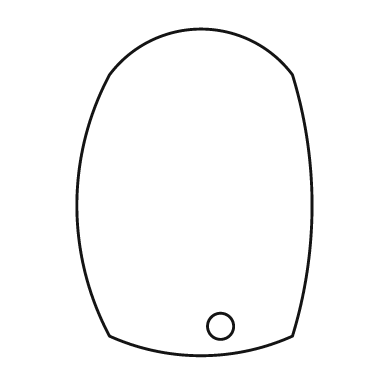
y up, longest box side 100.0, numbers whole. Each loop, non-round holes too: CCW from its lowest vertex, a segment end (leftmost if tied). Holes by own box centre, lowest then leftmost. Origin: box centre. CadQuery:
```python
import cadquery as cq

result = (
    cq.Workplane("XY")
    .moveTo(-26.0, -44.0)
    .threePointArc((2.0, -50.0), (30.0, -44.0))
    .threePointArc((36.0, -4.0), (30.0, 36.0))
    .threePointArc((2.0, 50.0), (-26.0, 36.0))
    .threePointArc((-36.0, -4.0), (-26.0, -44.0))
    .close()
    .moveTo(8.0, -41.0)
    .circle(4.0)
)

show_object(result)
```